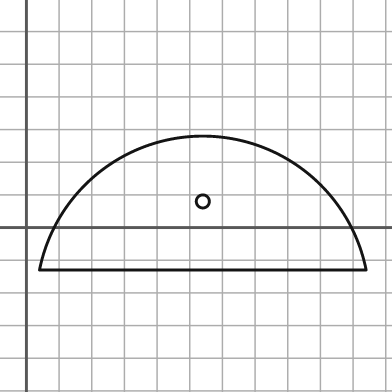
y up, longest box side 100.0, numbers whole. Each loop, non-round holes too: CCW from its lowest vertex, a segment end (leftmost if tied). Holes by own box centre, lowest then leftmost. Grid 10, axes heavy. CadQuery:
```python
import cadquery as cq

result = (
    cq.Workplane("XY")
    .moveTo(4.0, -13.0)
    .lineTo(104.0, -13.0)
    .threePointArc((54.0, 28.0), (4.0, -13.0))
    .close()
    .moveTo(54.0, 8.0)
    .circle(2.0)
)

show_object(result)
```